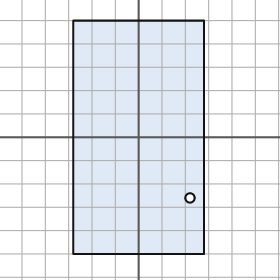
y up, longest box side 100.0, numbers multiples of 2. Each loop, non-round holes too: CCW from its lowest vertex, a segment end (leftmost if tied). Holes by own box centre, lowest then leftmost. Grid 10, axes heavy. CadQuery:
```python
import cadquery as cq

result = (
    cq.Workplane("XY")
    .moveTo(-28.0, -50.0)
    .lineTo(28.0, -50.0)
    .lineTo(28.0, 50.0)
    .lineTo(-28.0, 50.0)
    .close()
    .moveTo(22.0, -26.0)
    .circle(2.0)
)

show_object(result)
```